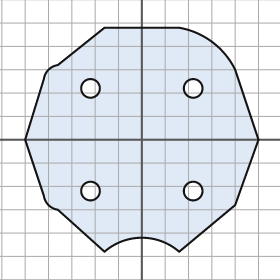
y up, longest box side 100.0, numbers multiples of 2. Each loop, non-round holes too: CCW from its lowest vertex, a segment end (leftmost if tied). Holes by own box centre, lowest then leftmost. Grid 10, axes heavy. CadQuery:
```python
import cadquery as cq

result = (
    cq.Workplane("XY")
    .moveTo(-16.0, -48.0)
    .threePointArc((0.0, -42.0), (16.0, -48.0))
    .lineTo(40.0, -28.0)
    .lineTo(50.0, 0.0)
    .lineTo(40.0, 30.0)
    .threePointArc((30.0, 42.0), (16.0, 48.0))
    .lineTo(-16.0, 48.0)
    .lineTo(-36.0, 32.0)
    .threePointArc((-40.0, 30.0), (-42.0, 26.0))
    .lineTo(-50.0, 0.0)
    .lineTo(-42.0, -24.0)
    .threePointArc((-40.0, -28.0), (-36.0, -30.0))
    .close()
    .moveTo(-22.0, -22.0)
    .circle(4.0)
    .moveTo(22.0, -22.0)
    .circle(4.0)
    .moveTo(-22.0, 22.0)
    .circle(4.0)
    .moveTo(22.0, 22.0)
    .circle(4.0)
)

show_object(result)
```